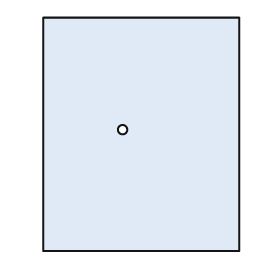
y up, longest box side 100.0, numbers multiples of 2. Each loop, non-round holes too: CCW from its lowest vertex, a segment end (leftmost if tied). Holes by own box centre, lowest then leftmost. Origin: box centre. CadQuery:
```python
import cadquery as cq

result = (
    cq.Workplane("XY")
    .moveTo(-42.0, -50.0)
    .lineTo(42.0, -50.0)
    .lineTo(42.0, 50.0)
    .lineTo(-42.0, 50.0)
    .close()
    .moveTo(-8.0, 2.0)
    .circle(2.0)
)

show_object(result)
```